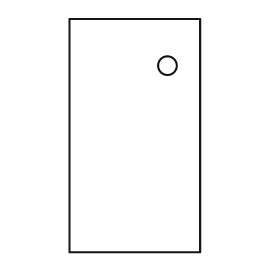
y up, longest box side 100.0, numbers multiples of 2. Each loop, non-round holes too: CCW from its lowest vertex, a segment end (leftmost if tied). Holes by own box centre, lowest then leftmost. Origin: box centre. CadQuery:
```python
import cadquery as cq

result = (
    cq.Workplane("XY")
    .moveTo(-28.0, -50.0)
    .lineTo(28.0, -50.0)
    .lineTo(28.0, 50.0)
    .lineTo(-28.0, 50.0)
    .close()
    .moveTo(14.0, 30.0)
    .circle(4.0)
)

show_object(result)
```